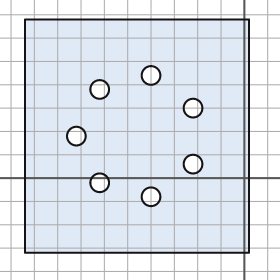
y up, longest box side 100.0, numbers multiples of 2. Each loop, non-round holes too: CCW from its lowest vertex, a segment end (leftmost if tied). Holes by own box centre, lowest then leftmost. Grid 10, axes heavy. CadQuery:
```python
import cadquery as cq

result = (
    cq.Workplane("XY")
    .moveTo(-94.0, -32.0)
    .lineTo(2.0, -32.0)
    .lineTo(2.0, 68.0)
    .lineTo(-94.0, 68.0)
    .close()
    .moveTo(-40.0, -8.0)
    .circle(4.0)
    .moveTo(-62.0, -2.0)
    .circle(4.0)
    .moveTo(-22.0, 6.0)
    .circle(4.0)
    .moveTo(-72.0, 18.0)
    .circle(4.0)
    .moveTo(-22.0, 30.0)
    .circle(4.0)
    .moveTo(-62.0, 38.0)
    .circle(4.0)
    .moveTo(-40.0, 44.0)
    .circle(4.0)
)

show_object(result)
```